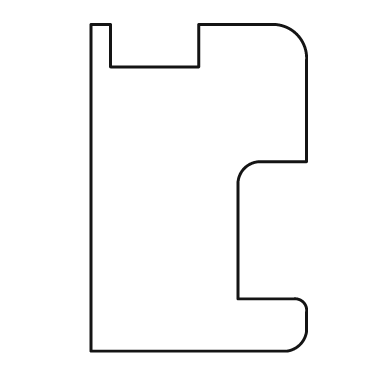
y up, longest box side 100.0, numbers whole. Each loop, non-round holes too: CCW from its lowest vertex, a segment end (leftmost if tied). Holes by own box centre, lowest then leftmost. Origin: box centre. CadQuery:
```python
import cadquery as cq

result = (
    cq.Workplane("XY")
    .moveTo(-33.0, -50.0)
    .lineTo(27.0, -50.0)
    .threePointArc((31.0, -48.0), (33.0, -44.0))
    .lineTo(33.0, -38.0)
    .threePointArc((32.0, -35.0), (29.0, -34.0))
    .lineTo(12.0, -34.0)
    .lineTo(12.0, 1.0)
    .threePointArc((14.0, 6.0), (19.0, 8.0))
    .lineTo(33.0, 8.0)
    .lineTo(33.0, 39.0)
    .threePointArc((30.0, 47.0), (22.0, 50.0))
    .lineTo(0.0, 50.0)
    .lineTo(0.0, 37.0)
    .lineTo(-27.0, 37.0)
    .lineTo(-27.0, 50.0)
    .lineTo(-33.0, 50.0)
    .close()
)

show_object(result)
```